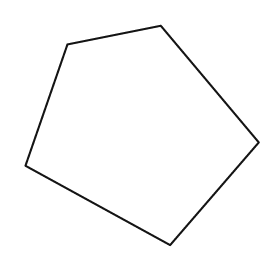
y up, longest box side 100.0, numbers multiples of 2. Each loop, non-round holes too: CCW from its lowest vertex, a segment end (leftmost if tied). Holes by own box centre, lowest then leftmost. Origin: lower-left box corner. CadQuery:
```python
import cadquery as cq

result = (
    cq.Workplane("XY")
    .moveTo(62.0, 0.0)
    .lineTo(100.0, 44.0)
    .lineTo(58.0, 94.0)
    .lineTo(18.0, 86.0)
    .lineTo(0.0, 34.0)
    .close()
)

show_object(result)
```